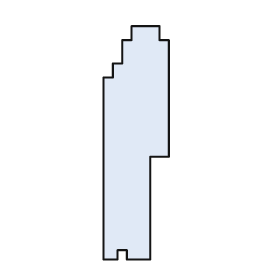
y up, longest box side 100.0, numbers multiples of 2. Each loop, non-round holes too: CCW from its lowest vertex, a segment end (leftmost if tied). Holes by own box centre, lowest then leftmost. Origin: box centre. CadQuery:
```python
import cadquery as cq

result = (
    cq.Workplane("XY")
    .moveTo(-14.0, -50.0)
    .lineTo(-8.0, -50.0)
    .lineTo(-8.0, -46.0)
    .lineTo(-4.0, -46.0)
    .lineTo(-4.0, -50.0)
    .lineTo(6.0, -50.0)
    .lineTo(6.0, -6.0)
    .lineTo(14.0, -6.0)
    .lineTo(14.0, 44.0)
    .lineTo(10.0, 44.0)
    .lineTo(10.0, 50.0)
    .lineTo(-2.0, 50.0)
    .lineTo(-2.0, 44.0)
    .lineTo(-6.0, 44.0)
    .lineTo(-6.0, 34.0)
    .lineTo(-10.0, 34.0)
    .lineTo(-10.0, 28.0)
    .lineTo(-14.0, 28.0)
    .close()
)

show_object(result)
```